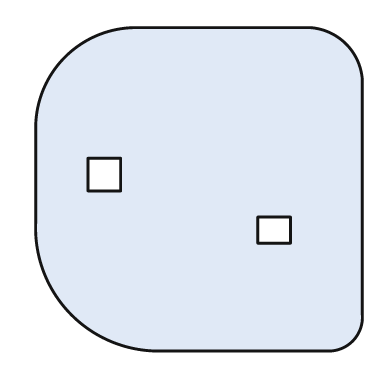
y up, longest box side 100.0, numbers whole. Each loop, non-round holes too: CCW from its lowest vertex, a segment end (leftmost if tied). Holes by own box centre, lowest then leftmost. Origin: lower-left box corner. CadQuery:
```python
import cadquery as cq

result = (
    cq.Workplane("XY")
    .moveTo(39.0, 0.0)
    .lineTo(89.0, 0.0)
    .threePointArc((97.0, 3.0), (100.0, 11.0))
    .lineTo(100.0, 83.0)
    .threePointArc((95.0, 94.0), (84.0, 99.0))
    .lineTo(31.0, 99.0)
    .threePointArc((9.0, 90.0), (0.0, 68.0))
    .lineTo(0.0, 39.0)
    .threePointArc((11.0, 11.0), (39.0, 0.0))
    .close()
    .moveTo(68.0, 33.0)
    .lineTo(78.0, 33.0)
    .lineTo(78.0, 41.0)
    .lineTo(68.0, 41.0)
    .close()
    .moveTo(16.0, 49.0)
    .lineTo(26.0, 49.0)
    .lineTo(26.0, 59.0)
    .lineTo(16.0, 59.0)
    .close()
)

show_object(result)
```